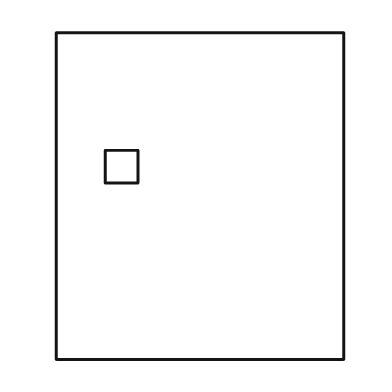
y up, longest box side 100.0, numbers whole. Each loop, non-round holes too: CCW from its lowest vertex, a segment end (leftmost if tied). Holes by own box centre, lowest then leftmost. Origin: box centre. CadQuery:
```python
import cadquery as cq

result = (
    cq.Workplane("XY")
    .moveTo(-44.0, -50.0)
    .lineTo(44.0, -50.0)
    .lineTo(44.0, 50.0)
    .lineTo(-44.0, 50.0)
    .close()
    .moveTo(-29.0, 4.0)
    .lineTo(-19.0, 4.0)
    .lineTo(-19.0, 14.0)
    .lineTo(-29.0, 14.0)
    .close()
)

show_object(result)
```